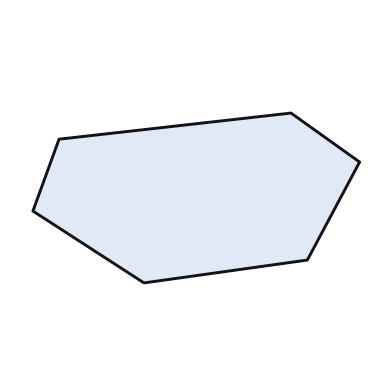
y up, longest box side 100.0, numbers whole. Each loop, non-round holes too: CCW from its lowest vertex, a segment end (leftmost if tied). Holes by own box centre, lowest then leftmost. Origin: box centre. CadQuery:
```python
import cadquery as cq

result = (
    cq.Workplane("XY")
    .moveTo(-16.0, -26.0)
    .lineTo(34.0, -19.0)
    .lineTo(50.0, 11.0)
    .lineTo(29.0, 26.0)
    .lineTo(-42.0, 18.0)
    .lineTo(-50.0, -4.0)
    .close()
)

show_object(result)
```